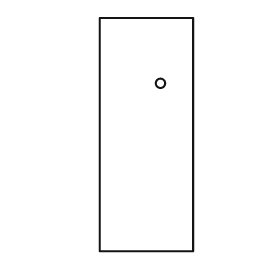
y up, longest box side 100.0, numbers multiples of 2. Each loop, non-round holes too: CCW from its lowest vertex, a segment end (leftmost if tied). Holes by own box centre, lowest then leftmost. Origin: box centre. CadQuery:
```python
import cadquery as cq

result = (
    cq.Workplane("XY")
    .moveTo(-20.0, -50.0)
    .lineTo(20.0, -50.0)
    .lineTo(20.0, 50.0)
    .lineTo(-20.0, 50.0)
    .close()
    .moveTo(6.0, 22.0)
    .circle(2.0)
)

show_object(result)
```